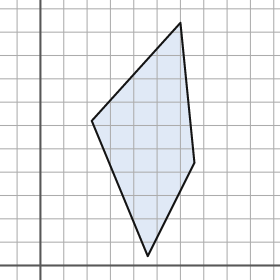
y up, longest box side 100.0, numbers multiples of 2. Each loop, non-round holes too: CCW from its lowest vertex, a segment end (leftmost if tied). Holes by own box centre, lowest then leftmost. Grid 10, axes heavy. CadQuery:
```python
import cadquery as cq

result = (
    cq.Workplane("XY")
    .moveTo(46.0, 4.0)
    .lineTo(66.0, 44.0)
    .lineTo(60.0, 104.0)
    .lineTo(22.0, 62.0)
    .close()
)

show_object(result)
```